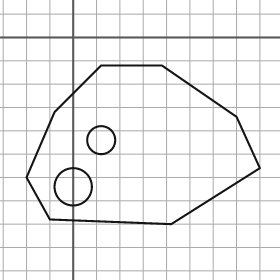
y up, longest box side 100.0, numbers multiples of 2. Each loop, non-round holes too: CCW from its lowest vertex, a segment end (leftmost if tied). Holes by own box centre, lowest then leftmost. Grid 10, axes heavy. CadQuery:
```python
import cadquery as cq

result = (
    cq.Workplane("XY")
    .moveTo(42.0, -80.0)
    .lineTo(80.0, -56.0)
    .lineTo(70.0, -34.0)
    .lineTo(38.0, -12.0)
    .lineTo(12.0, -12.0)
    .lineTo(-8.0, -32.0)
    .lineTo(-20.0, -60.0)
    .lineTo(-10.0, -78.0)
    .close()
    .moveTo(0.0, -64.0)
    .circle(8.0)
    .moveTo(12.0, -44.0)
    .circle(6.0)
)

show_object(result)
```